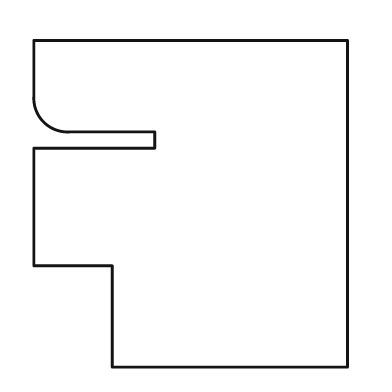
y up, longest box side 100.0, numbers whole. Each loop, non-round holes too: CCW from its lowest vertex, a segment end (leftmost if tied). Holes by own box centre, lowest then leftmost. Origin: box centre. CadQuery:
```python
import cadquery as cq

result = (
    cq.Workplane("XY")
    .moveTo(-24.0, -50.0)
    .lineTo(48.0, -50.0)
    .lineTo(48.0, 50.0)
    .lineTo(-48.0, 50.0)
    .lineTo(-48.0, 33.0)
    .threePointArc((-45.0, 25.0), (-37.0, 22.0))
    .lineTo(-11.0, 22.0)
    .lineTo(-11.0, 17.0)
    .lineTo(-48.0, 17.0)
    .lineTo(-48.0, -19.0)
    .lineTo(-24.0, -19.0)
    .close()
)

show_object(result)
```